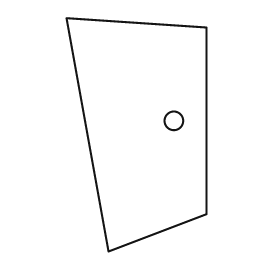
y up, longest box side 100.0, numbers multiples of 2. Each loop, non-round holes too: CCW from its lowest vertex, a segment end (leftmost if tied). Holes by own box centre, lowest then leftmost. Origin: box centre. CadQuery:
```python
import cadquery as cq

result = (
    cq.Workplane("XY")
    .moveTo(-12.0, -50.0)
    .lineTo(30.0, -34.0)
    .lineTo(30.0, 46.0)
    .lineTo(-30.0, 50.0)
    .close()
    .moveTo(16.0, 6.0)
    .circle(4.0)
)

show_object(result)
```